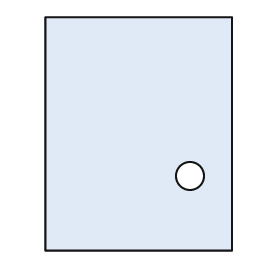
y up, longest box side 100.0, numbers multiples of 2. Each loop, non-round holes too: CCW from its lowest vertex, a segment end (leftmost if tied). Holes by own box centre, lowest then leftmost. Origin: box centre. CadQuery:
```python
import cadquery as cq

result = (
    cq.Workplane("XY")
    .moveTo(-40.0, -50.0)
    .lineTo(40.0, -50.0)
    .lineTo(40.0, 50.0)
    .lineTo(-40.0, 50.0)
    .close()
    .moveTo(22.0, -18.0)
    .circle(6.0)
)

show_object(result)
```